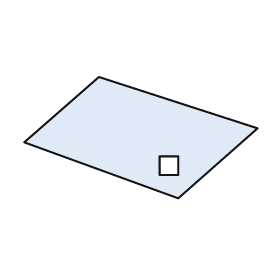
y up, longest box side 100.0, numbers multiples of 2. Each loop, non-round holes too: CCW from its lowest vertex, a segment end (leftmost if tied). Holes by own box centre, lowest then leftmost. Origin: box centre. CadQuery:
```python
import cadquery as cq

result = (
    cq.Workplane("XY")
    .moveTo(16.0, -26.0)
    .lineTo(50.0, 4.0)
    .lineTo(-18.0, 26.0)
    .lineTo(-50.0, -2.0)
    .close()
    .moveTo(8.0, -16.0)
    .lineTo(16.0, -16.0)
    .lineTo(16.0, -8.0)
    .lineTo(8.0, -8.0)
    .close()
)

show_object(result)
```